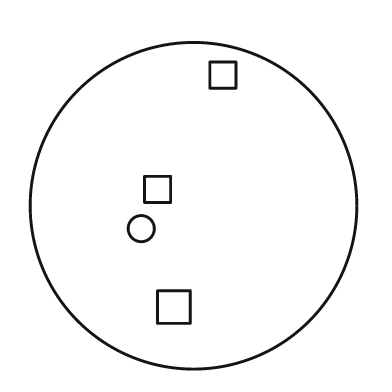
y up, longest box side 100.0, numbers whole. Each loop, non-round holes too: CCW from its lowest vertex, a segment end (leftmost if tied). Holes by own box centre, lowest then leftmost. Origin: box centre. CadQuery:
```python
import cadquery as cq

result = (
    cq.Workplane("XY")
    .moveTo(0.0, 0.0)
    .circle(50.0)
    .moveTo(-11.0, -36.0)
    .lineTo(-1.0, -36.0)
    .lineTo(-1.0, -26.0)
    .lineTo(-11.0, -26.0)
    .close()
    .moveTo(-16.0, -7.0)
    .circle(4.0)
    .moveTo(-15.0, 1.0)
    .lineTo(-7.0, 1.0)
    .lineTo(-7.0, 9.0)
    .lineTo(-15.0, 9.0)
    .close()
    .moveTo(5.0, 36.0)
    .lineTo(13.0, 36.0)
    .lineTo(13.0, 44.0)
    .lineTo(5.0, 44.0)
    .close()
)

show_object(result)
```